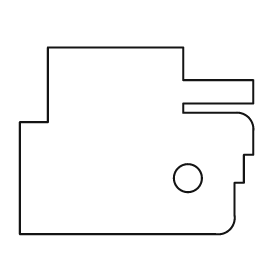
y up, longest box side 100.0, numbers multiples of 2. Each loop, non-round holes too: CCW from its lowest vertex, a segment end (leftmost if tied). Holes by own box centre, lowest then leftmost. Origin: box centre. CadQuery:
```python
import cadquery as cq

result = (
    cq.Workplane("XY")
    .moveTo(-50.0, -40.0)
    .lineTo(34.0, -40.0)
    .threePointArc((40.0, -38.0), (42.0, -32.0))
    .lineTo(42.0, -18.0)
    .lineTo(46.0, -18.0)
    .lineTo(46.0, -6.0)
    .lineTo(50.0, -6.0)
    .lineTo(50.0, 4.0)
    .threePointArc((48.0, 10.0), (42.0, 12.0))
    .lineTo(20.0, 12.0)
    .lineTo(20.0, 16.0)
    .lineTo(50.0, 16.0)
    .lineTo(50.0, 26.0)
    .lineTo(20.0, 26.0)
    .lineTo(20.0, 40.0)
    .lineTo(-38.0, 40.0)
    .lineTo(-38.0, 8.0)
    .lineTo(-50.0, 8.0)
    .close()
    .moveTo(22.0, -16.0)
    .circle(6.0)
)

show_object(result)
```